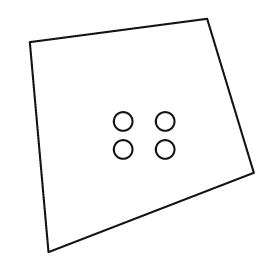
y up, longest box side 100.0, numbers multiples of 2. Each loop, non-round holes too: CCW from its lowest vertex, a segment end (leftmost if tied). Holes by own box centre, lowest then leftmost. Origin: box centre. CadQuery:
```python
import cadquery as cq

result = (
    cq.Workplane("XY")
    .moveTo(-40.0, -50.0)
    .lineTo(48.0, -16.0)
    .lineTo(28.0, 50.0)
    .lineTo(-48.0, 40.0)
    .close()
    .moveTo(-8.0, -6.0)
    .circle(4.0)
    .moveTo(10.0, -6.0)
    .circle(4.0)
    .moveTo(-8.0, 6.0)
    .circle(4.0)
    .moveTo(10.0, 6.0)
    .circle(4.0)
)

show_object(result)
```